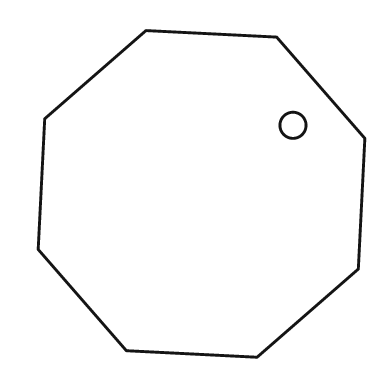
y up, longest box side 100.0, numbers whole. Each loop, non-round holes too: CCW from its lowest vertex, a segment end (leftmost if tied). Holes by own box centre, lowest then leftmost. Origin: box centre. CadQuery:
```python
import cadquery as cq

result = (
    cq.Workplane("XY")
    .moveTo(17.0, -50.0)
    .lineTo(48.0, -23.0)
    .lineTo(50.0, 17.0)
    .lineTo(23.0, 48.0)
    .lineTo(-17.0, 50.0)
    .lineTo(-48.0, 23.0)
    .lineTo(-50.0, -17.0)
    .lineTo(-23.0, -48.0)
    .close()
    .moveTo(28.0, 21.0)
    .circle(4.0)
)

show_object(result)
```